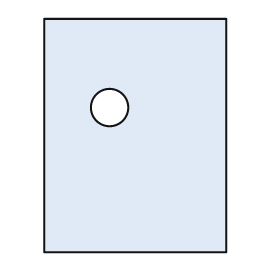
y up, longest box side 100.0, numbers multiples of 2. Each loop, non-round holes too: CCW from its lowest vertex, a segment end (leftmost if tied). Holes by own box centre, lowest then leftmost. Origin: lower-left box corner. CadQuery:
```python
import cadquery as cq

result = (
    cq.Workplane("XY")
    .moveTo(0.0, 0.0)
    .lineTo(78.0, 0.0)
    .lineTo(78.0, 100.0)
    .lineTo(0.0, 100.0)
    .close()
    .moveTo(28.0, 62.0)
    .circle(8.0)
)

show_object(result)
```